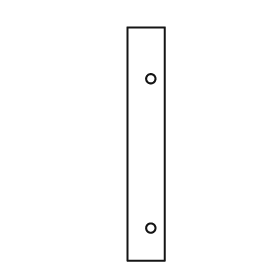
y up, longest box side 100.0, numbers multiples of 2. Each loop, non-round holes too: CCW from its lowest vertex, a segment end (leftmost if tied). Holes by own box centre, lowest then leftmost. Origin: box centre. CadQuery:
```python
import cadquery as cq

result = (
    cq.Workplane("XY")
    .moveTo(-8.0, -50.0)
    .lineTo(8.0, -50.0)
    .lineTo(8.0, 50.0)
    .lineTo(-8.0, 50.0)
    .close()
    .moveTo(2.0, -36.0)
    .circle(2.0)
    .moveTo(2.0, 28.0)
    .circle(2.0)
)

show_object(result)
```